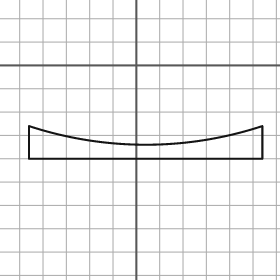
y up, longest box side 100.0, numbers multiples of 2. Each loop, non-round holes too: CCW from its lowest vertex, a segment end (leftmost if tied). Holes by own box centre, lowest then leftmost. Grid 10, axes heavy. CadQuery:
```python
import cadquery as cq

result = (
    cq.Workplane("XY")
    .moveTo(-46.0, -40.0)
    .lineTo(54.0, -40.0)
    .lineTo(54.0, -26.0)
    .threePointArc((4.0, -34.0), (-46.0, -26.0))
    .close()
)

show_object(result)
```